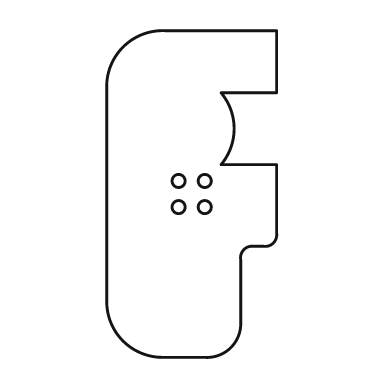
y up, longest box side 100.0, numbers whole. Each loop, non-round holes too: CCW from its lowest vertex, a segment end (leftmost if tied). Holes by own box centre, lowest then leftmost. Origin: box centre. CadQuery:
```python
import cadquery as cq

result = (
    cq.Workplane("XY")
    .moveTo(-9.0, -50.0)
    .lineTo(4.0, -50.0)
    .threePointArc((12.0, -47.0), (15.0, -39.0))
    .lineTo(15.0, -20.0)
    .threePointArc((16.0, -17.0), (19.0, -16.0))
    .lineTo(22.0, -16.0)
    .threePointArc((25.0, -15.0), (26.0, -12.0))
    .lineTo(26.0, 9.0)
    .lineTo(9.0, 9.0)
    .threePointArc((13.0, 20.0), (9.0, 31.0))
    .lineTo(26.0, 31.0)
    .lineTo(26.0, 50.0)
    .lineTo(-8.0, 50.0)
    .threePointArc((-21.0, 45.0), (-26.0, 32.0))
    .lineTo(-26.0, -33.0)
    .threePointArc((-21.0, -45.0), (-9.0, -50.0))
    .close()
    .moveTo(-4.0, -4.0)
    .circle(2.0)
    .moveTo(4.0, -4.0)
    .circle(2.0)
    .moveTo(-4.0, 4.0)
    .circle(2.0)
    .moveTo(4.0, 4.0)
    .circle(2.0)
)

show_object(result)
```